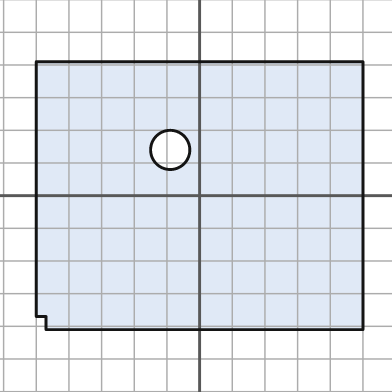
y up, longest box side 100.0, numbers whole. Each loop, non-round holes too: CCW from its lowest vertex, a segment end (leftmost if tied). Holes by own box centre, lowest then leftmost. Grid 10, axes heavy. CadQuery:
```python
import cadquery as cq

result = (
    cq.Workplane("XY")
    .moveTo(-47.0, -41.0)
    .lineTo(50.0, -41.0)
    .lineTo(50.0, 41.0)
    .lineTo(-50.0, 41.0)
    .lineTo(-50.0, -37.0)
    .lineTo(-47.0, -37.0)
    .close()
    .moveTo(-9.0, 14.0)
    .circle(6.0)
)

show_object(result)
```